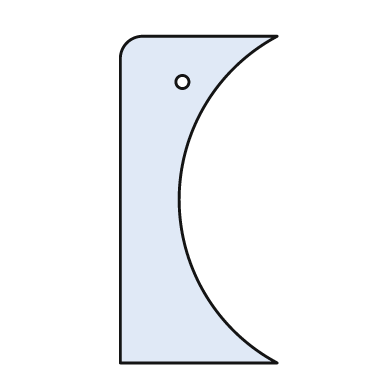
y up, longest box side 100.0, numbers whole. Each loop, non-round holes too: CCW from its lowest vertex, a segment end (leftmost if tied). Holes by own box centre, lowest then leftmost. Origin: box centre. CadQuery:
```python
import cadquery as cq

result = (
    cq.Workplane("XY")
    .moveTo(-24.0, -50.0)
    .lineTo(24.0, -50.0)
    .threePointArc((-6.0, 0.0), (24.0, 50.0))
    .lineTo(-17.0, 50.0)
    .threePointArc((-22.0, 48.0), (-24.0, 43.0))
    .close()
    .moveTo(-5.0, 36.0)
    .circle(2.0)
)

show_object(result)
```